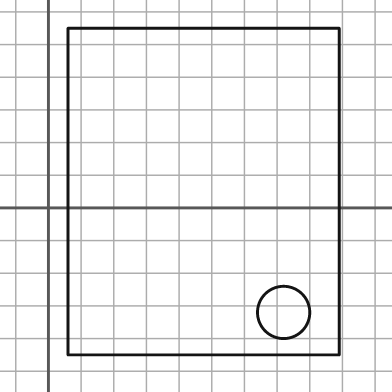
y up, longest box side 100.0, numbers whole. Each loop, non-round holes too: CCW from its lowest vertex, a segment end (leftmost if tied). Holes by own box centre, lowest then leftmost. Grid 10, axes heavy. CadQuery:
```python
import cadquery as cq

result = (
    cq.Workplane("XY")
    .moveTo(6.0, -45.0)
    .lineTo(89.0, -45.0)
    .lineTo(89.0, 55.0)
    .lineTo(6.0, 55.0)
    .close()
    .moveTo(72.0, -32.0)
    .circle(8.0)
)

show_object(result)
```